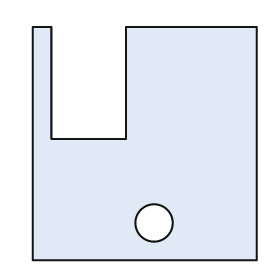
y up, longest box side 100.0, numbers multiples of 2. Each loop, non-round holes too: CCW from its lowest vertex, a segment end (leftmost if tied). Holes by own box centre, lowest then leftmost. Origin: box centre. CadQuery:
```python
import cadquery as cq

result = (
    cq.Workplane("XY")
    .moveTo(-48.0, -50.0)
    .lineTo(48.0, -50.0)
    .lineTo(48.0, 50.0)
    .lineTo(-8.0, 50.0)
    .lineTo(-8.0, 2.0)
    .lineTo(-40.0, 2.0)
    .lineTo(-40.0, 50.0)
    .lineTo(-48.0, 50.0)
    .close()
    .moveTo(4.0, -34.0)
    .circle(8.0)
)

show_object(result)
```